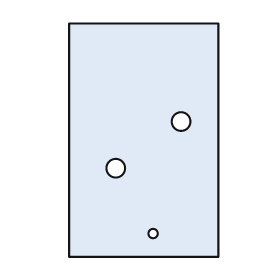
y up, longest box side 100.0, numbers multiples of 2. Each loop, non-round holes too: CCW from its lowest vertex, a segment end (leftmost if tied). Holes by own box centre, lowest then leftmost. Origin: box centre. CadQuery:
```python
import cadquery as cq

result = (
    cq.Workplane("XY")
    .moveTo(-32.0, -50.0)
    .lineTo(32.0, -50.0)
    .lineTo(32.0, 50.0)
    .lineTo(-32.0, 50.0)
    .close()
    .moveTo(4.0, -40.0)
    .circle(2.0)
    .moveTo(-12.0, -12.0)
    .circle(4.0)
    .moveTo(16.0, 8.0)
    .circle(4.0)
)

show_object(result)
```